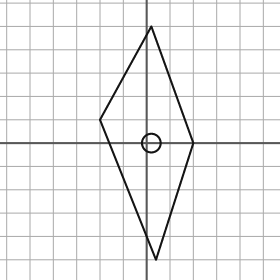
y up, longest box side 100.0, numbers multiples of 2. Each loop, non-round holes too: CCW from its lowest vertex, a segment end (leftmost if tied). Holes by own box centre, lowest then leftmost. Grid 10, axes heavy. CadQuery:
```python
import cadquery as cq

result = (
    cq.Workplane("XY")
    .moveTo(4.0, -50.0)
    .lineTo(20.0, 0.0)
    .lineTo(2.0, 50.0)
    .lineTo(-20.0, 10.0)
    .close()
    .moveTo(2.0, 0.0)
    .circle(4.0)
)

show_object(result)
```